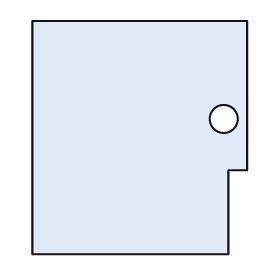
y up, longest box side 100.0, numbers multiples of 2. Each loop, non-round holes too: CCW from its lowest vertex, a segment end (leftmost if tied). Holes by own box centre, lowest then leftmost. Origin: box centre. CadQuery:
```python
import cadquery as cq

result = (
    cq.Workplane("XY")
    .moveTo(-46.0, -50.0)
    .lineTo(38.0, -50.0)
    .lineTo(38.0, -14.0)
    .lineTo(46.0, -14.0)
    .lineTo(46.0, 50.0)
    .lineTo(-46.0, 50.0)
    .close()
    .moveTo(36.0, 8.0)
    .circle(6.0)
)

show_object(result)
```